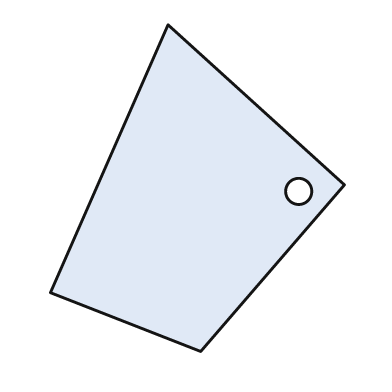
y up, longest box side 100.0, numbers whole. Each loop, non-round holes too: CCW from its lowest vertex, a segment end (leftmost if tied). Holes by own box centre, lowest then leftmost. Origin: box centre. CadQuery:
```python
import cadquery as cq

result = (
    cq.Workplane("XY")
    .moveTo(1.0, -50.0)
    .lineTo(45.0, 1.0)
    .lineTo(-9.0, 50.0)
    .lineTo(-45.0, -32.0)
    .close()
    .moveTo(31.0, -1.0)
    .circle(4.0)
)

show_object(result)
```